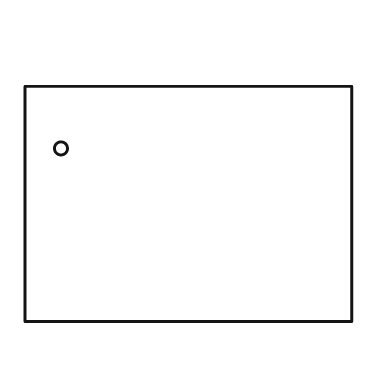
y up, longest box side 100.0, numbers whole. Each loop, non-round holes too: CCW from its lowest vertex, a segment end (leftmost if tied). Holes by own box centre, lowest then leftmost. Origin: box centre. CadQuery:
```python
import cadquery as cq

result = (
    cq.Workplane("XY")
    .moveTo(-50.0, -36.0)
    .lineTo(50.0, -36.0)
    .lineTo(50.0, 36.0)
    .lineTo(-50.0, 36.0)
    .close()
    .moveTo(-39.0, 17.0)
    .circle(2.0)
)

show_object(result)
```